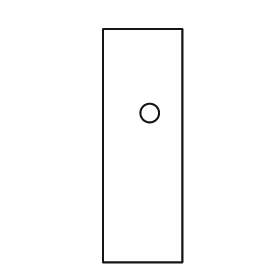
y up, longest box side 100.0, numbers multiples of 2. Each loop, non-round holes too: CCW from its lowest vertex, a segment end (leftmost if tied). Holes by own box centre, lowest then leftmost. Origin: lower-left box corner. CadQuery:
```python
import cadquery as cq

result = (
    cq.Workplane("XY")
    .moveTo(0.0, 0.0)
    .lineTo(34.0, 0.0)
    .lineTo(34.0, 100.0)
    .lineTo(0.0, 100.0)
    .close()
    .moveTo(20.0, 64.0)
    .circle(4.0)
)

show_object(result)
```